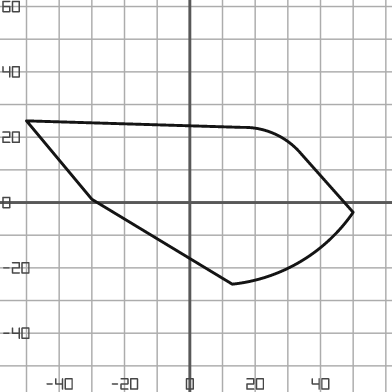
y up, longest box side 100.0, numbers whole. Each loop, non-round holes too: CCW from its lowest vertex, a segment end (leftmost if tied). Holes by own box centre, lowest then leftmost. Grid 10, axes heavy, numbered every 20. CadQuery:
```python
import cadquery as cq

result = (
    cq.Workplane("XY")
    .moveTo(13.0, -25.0)
    .threePointArc((34.0, -18.0), (50.0, -3.0))
    .lineTo(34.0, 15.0)
    .threePointArc((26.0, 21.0), (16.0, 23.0))
    .lineTo(-50.0, 25.0)
    .lineTo(-30.0, 1.0)
    .close()
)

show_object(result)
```